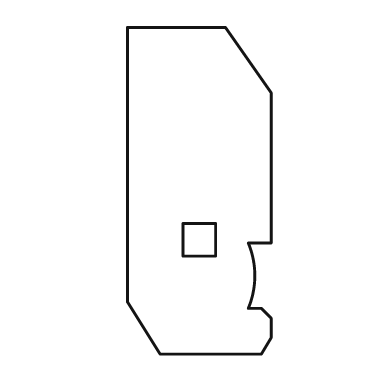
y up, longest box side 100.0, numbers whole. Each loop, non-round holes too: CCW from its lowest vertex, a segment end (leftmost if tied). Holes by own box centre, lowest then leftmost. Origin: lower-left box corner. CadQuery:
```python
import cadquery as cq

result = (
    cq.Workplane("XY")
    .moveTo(10.0, 0.0)
    .lineTo(41.0, 0.0)
    .lineTo(44.0, 5.0)
    .lineTo(44.0, 11.0)
    .lineTo(41.0, 14.0)
    .lineTo(37.0, 14.0)
    .threePointArc((39.0, 24.0), (37.0, 34.0))
    .lineTo(44.0, 34.0)
    .lineTo(44.0, 80.0)
    .lineTo(30.0, 100.0)
    .lineTo(0.0, 100.0)
    .lineTo(0.0, 16.0)
    .close()
    .moveTo(17.0, 30.0)
    .lineTo(27.0, 30.0)
    .lineTo(27.0, 40.0)
    .lineTo(17.0, 40.0)
    .close()
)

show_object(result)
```